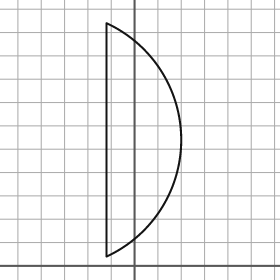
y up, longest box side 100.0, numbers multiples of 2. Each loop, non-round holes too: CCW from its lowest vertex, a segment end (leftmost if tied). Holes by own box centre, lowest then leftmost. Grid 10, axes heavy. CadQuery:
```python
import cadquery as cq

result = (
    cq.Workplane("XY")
    .moveTo(-12.0, 4.0)
    .threePointArc((20.0, 54.0), (-12.0, 104.0))
    .close()
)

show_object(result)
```